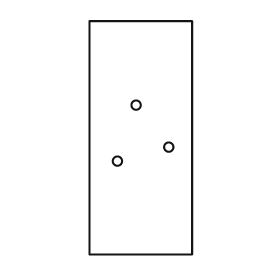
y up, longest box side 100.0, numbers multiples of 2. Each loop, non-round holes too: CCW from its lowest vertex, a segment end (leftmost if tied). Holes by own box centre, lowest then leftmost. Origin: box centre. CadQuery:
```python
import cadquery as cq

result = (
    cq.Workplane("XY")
    .moveTo(-22.0, -50.0)
    .lineTo(22.0, -50.0)
    .lineTo(22.0, 50.0)
    .lineTo(-22.0, 50.0)
    .close()
    .moveTo(-10.0, -10.0)
    .circle(2.0)
    .moveTo(12.0, -4.0)
    .circle(2.0)
    .moveTo(-2.0, 14.0)
    .circle(2.0)
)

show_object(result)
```